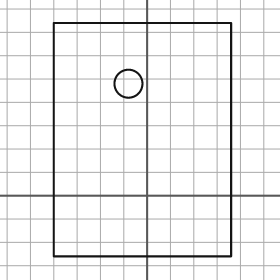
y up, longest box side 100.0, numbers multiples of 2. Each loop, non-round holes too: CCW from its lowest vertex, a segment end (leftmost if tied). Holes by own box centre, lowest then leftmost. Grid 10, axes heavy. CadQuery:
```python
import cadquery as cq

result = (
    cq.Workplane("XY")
    .moveTo(-40.0, -26.0)
    .lineTo(36.0, -26.0)
    .lineTo(36.0, 74.0)
    .lineTo(-40.0, 74.0)
    .close()
    .moveTo(-8.0, 48.0)
    .circle(6.0)
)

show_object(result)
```